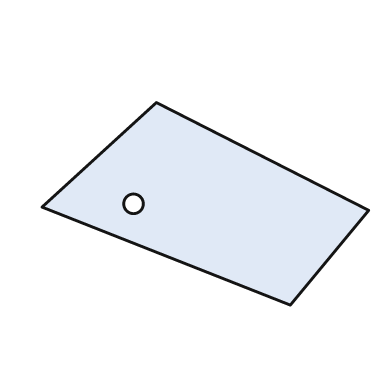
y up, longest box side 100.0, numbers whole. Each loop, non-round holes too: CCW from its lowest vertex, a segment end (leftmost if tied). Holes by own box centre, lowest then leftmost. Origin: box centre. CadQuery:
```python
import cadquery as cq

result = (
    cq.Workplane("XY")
    .moveTo(26.0, -31.0)
    .lineTo(50.0, -2.0)
    .lineTo(-15.0, 31.0)
    .lineTo(-50.0, -1.0)
    .close()
    .moveTo(-22.0, 0.0)
    .circle(3.0)
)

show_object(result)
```